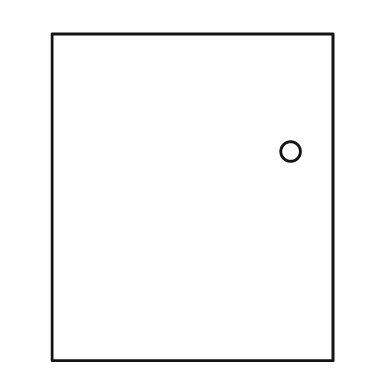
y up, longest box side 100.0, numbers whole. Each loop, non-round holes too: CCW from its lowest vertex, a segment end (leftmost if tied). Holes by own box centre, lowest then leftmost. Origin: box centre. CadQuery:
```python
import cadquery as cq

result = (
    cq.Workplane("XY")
    .moveTo(-43.0, -50.0)
    .lineTo(43.0, -50.0)
    .lineTo(43.0, 50.0)
    .lineTo(-43.0, 50.0)
    .close()
    .moveTo(30.0, 14.0)
    .circle(3.0)
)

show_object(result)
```